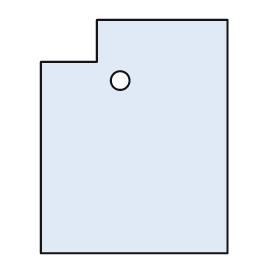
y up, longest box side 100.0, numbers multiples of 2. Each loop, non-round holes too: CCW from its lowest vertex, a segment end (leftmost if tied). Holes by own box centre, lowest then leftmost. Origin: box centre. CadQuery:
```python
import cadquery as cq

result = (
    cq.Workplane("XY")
    .moveTo(-40.0, -50.0)
    .lineTo(40.0, -50.0)
    .lineTo(40.0, 50.0)
    .lineTo(-16.0, 50.0)
    .lineTo(-16.0, 32.0)
    .lineTo(-40.0, 32.0)
    .close()
    .moveTo(-6.0, 24.0)
    .circle(4.0)
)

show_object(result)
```